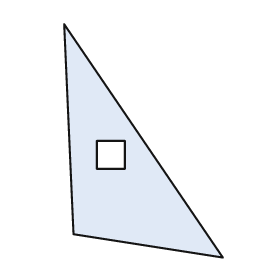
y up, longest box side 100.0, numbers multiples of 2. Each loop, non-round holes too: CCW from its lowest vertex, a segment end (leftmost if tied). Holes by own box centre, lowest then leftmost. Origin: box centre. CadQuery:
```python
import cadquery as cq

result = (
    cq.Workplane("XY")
    .moveTo(34.0, -50.0)
    .lineTo(-34.0, 50.0)
    .lineTo(-30.0, -40.0)
    .close()
    .moveTo(-20.0, -12.0)
    .lineTo(-8.0, -12.0)
    .lineTo(-8.0, 0.0)
    .lineTo(-20.0, 0.0)
    .close()
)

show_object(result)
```